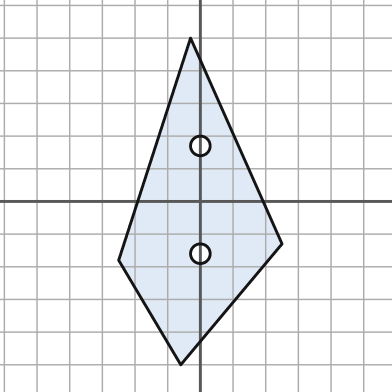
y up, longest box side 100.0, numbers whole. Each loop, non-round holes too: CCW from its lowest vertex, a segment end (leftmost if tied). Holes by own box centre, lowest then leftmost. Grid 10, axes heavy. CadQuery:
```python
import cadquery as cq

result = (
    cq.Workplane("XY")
    .moveTo(-6.0, -50.0)
    .lineTo(25.0, -13.0)
    .lineTo(-3.0, 50.0)
    .lineTo(-25.0, -18.0)
    .close()
    .moveTo(0.0, -16.0)
    .circle(3.0)
    .moveTo(0.0, 17.0)
    .circle(3.0)
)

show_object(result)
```